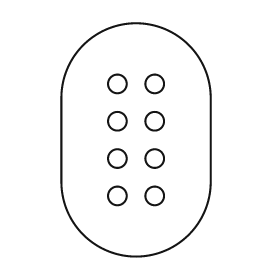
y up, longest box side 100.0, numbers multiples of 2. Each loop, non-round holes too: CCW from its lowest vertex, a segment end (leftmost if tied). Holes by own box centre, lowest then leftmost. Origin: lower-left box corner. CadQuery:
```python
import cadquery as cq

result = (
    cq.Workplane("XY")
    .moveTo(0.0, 32.0)
    .threePointArc((32.0, 0.0), (64.0, 32.0))
    .lineTo(64.0, 68.0)
    .threePointArc((32.0, 100.0), (0.0, 68.0))
    .close()
    .moveTo(24.0, 26.0)
    .circle(4.0)
    .moveTo(40.0, 26.0)
    .circle(4.0)
    .moveTo(24.0, 42.0)
    .circle(4.0)
    .moveTo(40.0, 42.0)
    .circle(4.0)
    .moveTo(24.0, 58.0)
    .circle(4.0)
    .moveTo(40.0, 58.0)
    .circle(4.0)
    .moveTo(24.0, 74.0)
    .circle(4.0)
    .moveTo(40.0, 74.0)
    .circle(4.0)
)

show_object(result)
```